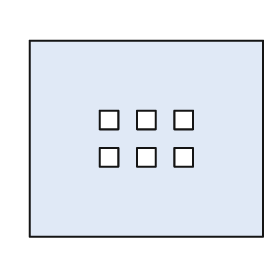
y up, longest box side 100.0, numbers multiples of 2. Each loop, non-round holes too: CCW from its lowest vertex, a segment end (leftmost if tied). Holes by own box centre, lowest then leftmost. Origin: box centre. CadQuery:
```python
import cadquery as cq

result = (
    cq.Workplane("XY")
    .moveTo(-50.0, -42.0)
    .lineTo(50.0, -42.0)
    .lineTo(50.0, 42.0)
    .lineTo(-50.0, 42.0)
    .close()
    .moveTo(-20.0, -12.0)
    .lineTo(-12.0, -12.0)
    .lineTo(-12.0, -4.0)
    .lineTo(-20.0, -4.0)
    .close()
    .moveTo(-4.0, -12.0)
    .lineTo(4.0, -12.0)
    .lineTo(4.0, -4.0)
    .lineTo(-4.0, -4.0)
    .close()
    .moveTo(12.0, -12.0)
    .lineTo(20.0, -12.0)
    .lineTo(20.0, -4.0)
    .lineTo(12.0, -4.0)
    .close()
    .moveTo(-20.0, 4.0)
    .lineTo(-12.0, 4.0)
    .lineTo(-12.0, 12.0)
    .lineTo(-20.0, 12.0)
    .close()
    .moveTo(-4.0, 4.0)
    .lineTo(4.0, 4.0)
    .lineTo(4.0, 12.0)
    .lineTo(-4.0, 12.0)
    .close()
    .moveTo(12.0, 4.0)
    .lineTo(20.0, 4.0)
    .lineTo(20.0, 12.0)
    .lineTo(12.0, 12.0)
    .close()
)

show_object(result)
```